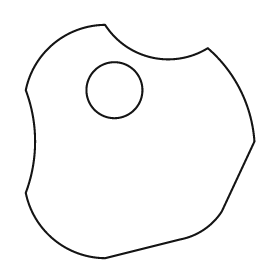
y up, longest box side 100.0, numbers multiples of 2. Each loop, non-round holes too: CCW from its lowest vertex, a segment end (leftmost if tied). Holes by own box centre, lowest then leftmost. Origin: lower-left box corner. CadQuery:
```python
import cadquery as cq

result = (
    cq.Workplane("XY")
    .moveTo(34.0, 0.0)
    .lineTo(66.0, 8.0)
    .threePointArc((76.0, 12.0), (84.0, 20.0))
    .lineTo(98.0, 50.0)
    .threePointArc((92.0, 72.0), (78.0, 90.0))
    .threePointArc((54.0, 86.0), (34.0, 100.0))
    .threePointArc((12.0, 92.0), (0.0, 72.0))
    .threePointArc((4.0, 50.0), (0.0, 28.0))
    .threePointArc((12.0, 8.0), (34.0, 0.0))
    .close()
    .moveTo(38.0, 72.0)
    .circle(12.0)
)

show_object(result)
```